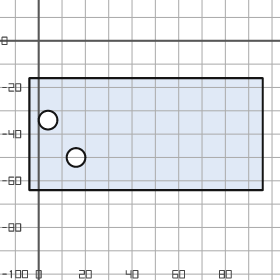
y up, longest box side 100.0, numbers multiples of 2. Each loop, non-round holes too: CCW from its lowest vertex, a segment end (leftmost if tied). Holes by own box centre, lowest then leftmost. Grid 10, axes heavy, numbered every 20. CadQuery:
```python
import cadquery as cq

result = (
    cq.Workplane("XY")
    .moveTo(-4.0, -64.0)
    .lineTo(96.0, -64.0)
    .lineTo(96.0, -16.0)
    .lineTo(-4.0, -16.0)
    .close()
    .moveTo(16.0, -50.0)
    .circle(4.0)
    .moveTo(4.0, -34.0)
    .circle(4.0)
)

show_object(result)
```